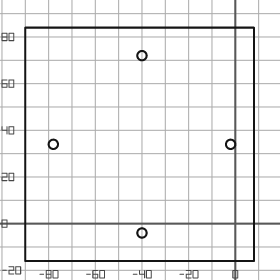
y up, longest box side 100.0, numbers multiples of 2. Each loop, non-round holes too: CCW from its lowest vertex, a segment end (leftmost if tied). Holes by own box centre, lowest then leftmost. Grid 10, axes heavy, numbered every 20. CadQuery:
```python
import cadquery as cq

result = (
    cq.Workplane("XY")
    .moveTo(-90.0, -16.0)
    .lineTo(8.0, -16.0)
    .lineTo(8.0, 84.0)
    .lineTo(-90.0, 84.0)
    .close()
    .moveTo(-40.0, -4.0)
    .circle(2.0)
    .moveTo(-78.0, 34.0)
    .circle(2.0)
    .moveTo(-2.0, 34.0)
    .circle(2.0)
    .moveTo(-40.0, 72.0)
    .circle(2.0)
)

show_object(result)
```